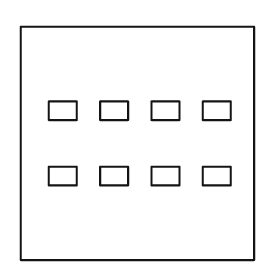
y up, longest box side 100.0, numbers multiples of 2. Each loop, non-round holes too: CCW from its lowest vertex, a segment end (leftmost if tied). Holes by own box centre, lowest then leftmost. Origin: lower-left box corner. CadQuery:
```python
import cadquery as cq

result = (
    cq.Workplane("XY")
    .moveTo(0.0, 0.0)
    .lineTo(100.0, 0.0)
    .lineTo(100.0, 100.0)
    .lineTo(0.0, 100.0)
    .close()
    .moveTo(12.0, 32.0)
    .lineTo(24.0, 32.0)
    .lineTo(24.0, 40.0)
    .lineTo(12.0, 40.0)
    .close()
    .moveTo(34.0, 32.0)
    .lineTo(46.0, 32.0)
    .lineTo(46.0, 40.0)
    .lineTo(34.0, 40.0)
    .close()
    .moveTo(56.0, 32.0)
    .lineTo(68.0, 32.0)
    .lineTo(68.0, 40.0)
    .lineTo(56.0, 40.0)
    .close()
    .moveTo(78.0, 32.0)
    .lineTo(90.0, 32.0)
    .lineTo(90.0, 40.0)
    .lineTo(78.0, 40.0)
    .close()
    .moveTo(12.0, 60.0)
    .lineTo(24.0, 60.0)
    .lineTo(24.0, 68.0)
    .lineTo(12.0, 68.0)
    .close()
    .moveTo(34.0, 60.0)
    .lineTo(46.0, 60.0)
    .lineTo(46.0, 68.0)
    .lineTo(34.0, 68.0)
    .close()
    .moveTo(56.0, 60.0)
    .lineTo(68.0, 60.0)
    .lineTo(68.0, 68.0)
    .lineTo(56.0, 68.0)
    .close()
    .moveTo(78.0, 60.0)
    .lineTo(90.0, 60.0)
    .lineTo(90.0, 68.0)
    .lineTo(78.0, 68.0)
    .close()
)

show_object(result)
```